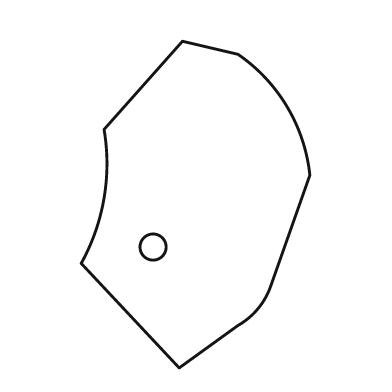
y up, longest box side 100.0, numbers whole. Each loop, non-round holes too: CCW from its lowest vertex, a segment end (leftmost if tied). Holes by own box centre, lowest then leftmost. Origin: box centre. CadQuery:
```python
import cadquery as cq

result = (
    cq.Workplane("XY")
    .moveTo(-5.0, -50.0)
    .lineTo(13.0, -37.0)
    .threePointArc((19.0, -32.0), (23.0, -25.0))
    .lineTo(35.0, 9.0)
    .threePointArc((28.0, 30.0), (13.0, 46.0))
    .lineTo(-4.0, 50.0)
    .lineTo(-28.0, 23.0)
    .threePointArc((-28.0, 2.0), (-35.0, -18.0))
    .close()
    .moveTo(-13.0, -13.0)
    .circle(4.0)
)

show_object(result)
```